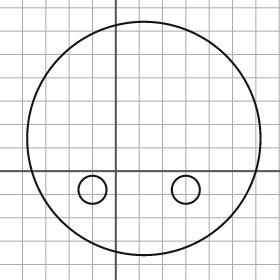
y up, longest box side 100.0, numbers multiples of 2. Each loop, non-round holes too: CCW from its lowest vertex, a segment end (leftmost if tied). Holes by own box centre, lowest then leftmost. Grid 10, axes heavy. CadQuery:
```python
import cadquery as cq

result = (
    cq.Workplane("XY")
    .moveTo(12.0, 14.0)
    .circle(50.0)
    .moveTo(-10.0, -8.0)
    .circle(6.0)
    .moveTo(30.0, -8.0)
    .circle(6.0)
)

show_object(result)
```